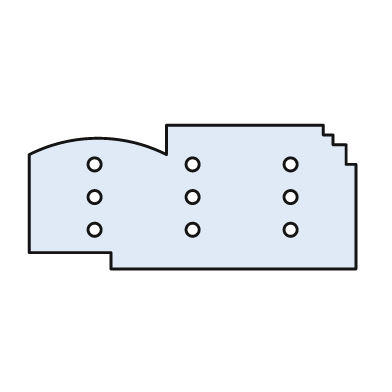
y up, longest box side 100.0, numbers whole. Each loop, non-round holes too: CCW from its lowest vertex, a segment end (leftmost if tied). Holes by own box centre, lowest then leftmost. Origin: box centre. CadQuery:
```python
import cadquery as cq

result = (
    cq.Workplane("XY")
    .moveTo(-25.0, -22.0)
    .lineTo(50.0, -22.0)
    .lineTo(50.0, 10.0)
    .lineTo(47.0, 10.0)
    .lineTo(47.0, 16.0)
    .lineTo(43.0, 16.0)
    .lineTo(43.0, 19.0)
    .lineTo(40.0, 19.0)
    .lineTo(40.0, 22.0)
    .lineTo(-8.0, 22.0)
    .lineTo(-8.0, 13.0)
    .threePointArc((-29.0, 18.0), (-50.0, 13.0))
    .lineTo(-50.0, -17.0)
    .lineTo(-25.0, -17.0)
    .close()
    .moveTo(-30.0, -10.0)
    .circle(2.0)
    .moveTo(0.0, -10.0)
    .circle(2.0)
    .moveTo(30.0, -10.0)
    .circle(2.0)
    .moveTo(-30.0, 0.0)
    .circle(2.0)
    .moveTo(0.0, 0.0)
    .circle(2.0)
    .moveTo(30.0, 0.0)
    .circle(2.0)
    .moveTo(-30.0, 10.0)
    .circle(2.0)
    .moveTo(0.0, 10.0)
    .circle(2.0)
    .moveTo(30.0, 10.0)
    .circle(2.0)
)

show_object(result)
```